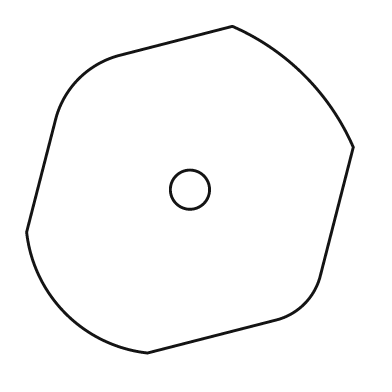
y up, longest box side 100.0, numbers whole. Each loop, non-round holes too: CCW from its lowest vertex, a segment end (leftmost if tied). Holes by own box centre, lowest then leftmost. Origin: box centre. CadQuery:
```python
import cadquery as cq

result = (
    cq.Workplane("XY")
    .moveTo(-13.0, -50.0)
    .lineTo(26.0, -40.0)
    .threePointArc((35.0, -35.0), (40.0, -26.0))
    .lineTo(50.0, 13.0)
    .threePointArc((35.0, 35.0), (13.0, 50.0))
    .lineTo(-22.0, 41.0)
    .threePointArc((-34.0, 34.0), (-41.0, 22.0))
    .lineTo(-50.0, -13.0)
    .threePointArc((-38.0, -38.0), (-13.0, -50.0))
    .close()
    .moveTo(0.0, 0.0)
    .circle(6.0)
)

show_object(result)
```